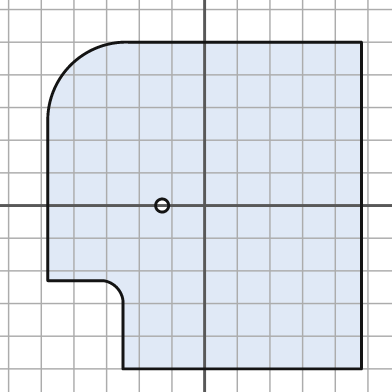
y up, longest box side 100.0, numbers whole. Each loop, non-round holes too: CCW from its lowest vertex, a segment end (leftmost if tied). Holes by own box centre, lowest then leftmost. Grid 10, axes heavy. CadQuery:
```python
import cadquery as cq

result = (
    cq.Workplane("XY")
    .moveTo(-25.0, -50.0)
    .lineTo(48.0, -50.0)
    .lineTo(48.0, 50.0)
    .lineTo(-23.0, 50.0)
    .threePointArc((-41.0, 43.0), (-48.0, 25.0))
    .lineTo(-48.0, -23.0)
    .lineTo(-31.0, -23.0)
    .threePointArc((-27.0, -25.0), (-25.0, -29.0))
    .close()
    .moveTo(-13.0, 0.0)
    .circle(2.0)
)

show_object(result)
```